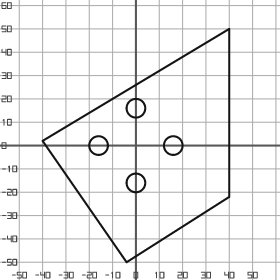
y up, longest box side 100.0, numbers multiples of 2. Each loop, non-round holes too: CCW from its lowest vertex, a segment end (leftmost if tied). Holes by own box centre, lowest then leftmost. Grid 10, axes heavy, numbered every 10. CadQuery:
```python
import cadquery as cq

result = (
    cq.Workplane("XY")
    .moveTo(-4.0, -50.0)
    .lineTo(40.0, -22.0)
    .lineTo(40.0, 50.0)
    .lineTo(-40.0, 2.0)
    .close()
    .moveTo(0.0, -16.0)
    .circle(4.0)
    .moveTo(-16.0, 0.0)
    .circle(4.0)
    .moveTo(16.0, 0.0)
    .circle(4.0)
    .moveTo(0.0, 16.0)
    .circle(4.0)
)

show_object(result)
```